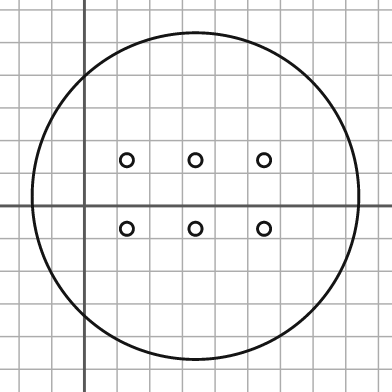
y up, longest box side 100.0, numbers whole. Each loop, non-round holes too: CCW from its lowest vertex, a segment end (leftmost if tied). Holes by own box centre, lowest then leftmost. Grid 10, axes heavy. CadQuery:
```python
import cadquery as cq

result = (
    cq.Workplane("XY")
    .moveTo(34.0, 3.0)
    .circle(50.0)
    .moveTo(13.0, -7.0)
    .circle(2.0)
    .moveTo(34.0, -7.0)
    .circle(2.0)
    .moveTo(55.0, -7.0)
    .circle(2.0)
    .moveTo(13.0, 14.0)
    .circle(2.0)
    .moveTo(34.0, 14.0)
    .circle(2.0)
    .moveTo(55.0, 14.0)
    .circle(2.0)
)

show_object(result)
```